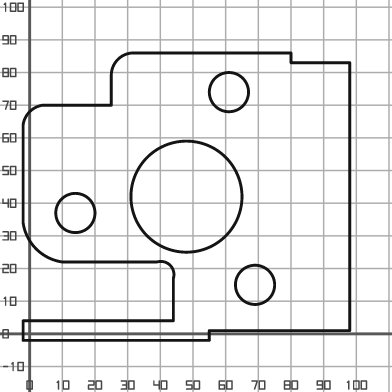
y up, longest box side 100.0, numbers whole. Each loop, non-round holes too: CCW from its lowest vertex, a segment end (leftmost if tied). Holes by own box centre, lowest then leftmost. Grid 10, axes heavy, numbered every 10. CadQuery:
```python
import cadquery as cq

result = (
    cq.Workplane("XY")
    .moveTo(-2.0, -2.0)
    .lineTo(55.0, -2.0)
    .lineTo(55.0, 1.0)
    .lineTo(98.0, 1.0)
    .lineTo(98.0, 83.0)
    .lineTo(80.0, 83.0)
    .lineTo(80.0, 86.0)
    .lineTo(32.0, 86.0)
    .threePointArc((27.0, 84.0), (25.0, 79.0))
    .lineTo(25.0, 70.0)
    .lineTo(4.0, 70.0)
    .threePointArc((0.0, 68.0), (-2.0, 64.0))
    .lineTo(-2.0, 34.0)
    .threePointArc((2.0, 26.0), (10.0, 22.0))
    .lineTo(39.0, 22.0)
    .threePointArc((43.0, 21.0), (44.0, 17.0))
    .lineTo(44.0, 4.0)
    .lineTo(-2.0, 4.0)
    .close()
    .moveTo(69.0, 15.0)
    .circle(6.0)
    .moveTo(14.0, 37.0)
    .circle(6.0)
    .moveTo(48.0, 42.0)
    .circle(17.0)
    .moveTo(61.0, 74.0)
    .circle(6.0)
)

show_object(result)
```